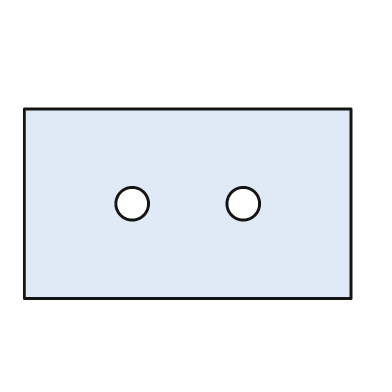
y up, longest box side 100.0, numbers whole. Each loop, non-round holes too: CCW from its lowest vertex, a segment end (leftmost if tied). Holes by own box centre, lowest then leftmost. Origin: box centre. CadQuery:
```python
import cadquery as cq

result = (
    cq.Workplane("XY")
    .moveTo(-50.0, -29.0)
    .lineTo(50.0, -29.0)
    .lineTo(50.0, 29.0)
    .lineTo(-50.0, 29.0)
    .close()
    .moveTo(-17.0, 0.0)
    .circle(5.0)
    .moveTo(17.0, 0.0)
    .circle(5.0)
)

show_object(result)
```